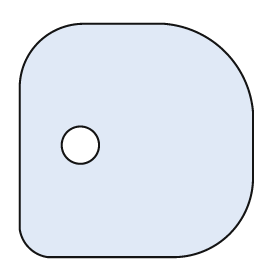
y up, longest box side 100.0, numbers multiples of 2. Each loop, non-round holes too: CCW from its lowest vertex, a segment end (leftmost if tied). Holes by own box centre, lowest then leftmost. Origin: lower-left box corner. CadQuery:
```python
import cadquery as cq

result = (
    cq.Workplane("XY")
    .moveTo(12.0, 0.0)
    .lineTo(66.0, 0.0)
    .threePointArc((90.0, 10.0), (100.0, 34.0))
    .lineTo(100.0, 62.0)
    .threePointArc((88.0, 88.0), (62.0, 100.0))
    .lineTo(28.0, 100.0)
    .threePointArc((8.0, 92.0), (0.0, 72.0))
    .lineTo(0.0, 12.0)
    .threePointArc((4.0, 4.0), (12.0, 0.0))
    .close()
    .moveTo(26.0, 48.0)
    .circle(8.0)
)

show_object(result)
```